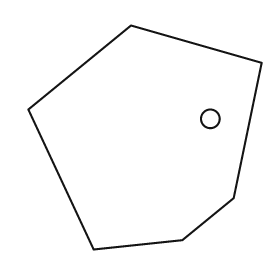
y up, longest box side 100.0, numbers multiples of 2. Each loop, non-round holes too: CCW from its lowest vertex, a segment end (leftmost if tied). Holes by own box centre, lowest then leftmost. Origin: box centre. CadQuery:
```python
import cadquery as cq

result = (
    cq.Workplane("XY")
    .moveTo(-22.0, -48.0)
    .lineTo(16.0, -44.0)
    .lineTo(38.0, -26.0)
    .lineTo(50.0, 32.0)
    .lineTo(-6.0, 48.0)
    .lineTo(-50.0, 12.0)
    .close()
    .moveTo(28.0, 8.0)
    .circle(4.0)
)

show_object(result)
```